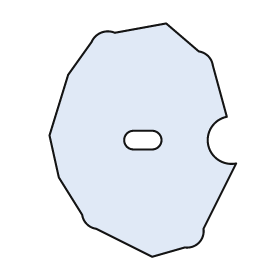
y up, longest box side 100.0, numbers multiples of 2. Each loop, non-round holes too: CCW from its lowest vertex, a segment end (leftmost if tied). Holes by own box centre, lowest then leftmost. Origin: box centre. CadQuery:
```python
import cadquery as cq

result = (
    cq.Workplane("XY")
    .moveTo(4.0, -50.0)
    .lineTo(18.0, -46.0)
    .threePointArc((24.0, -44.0), (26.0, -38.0))
    .lineTo(40.0, -10.0)
    .threePointArc((28.0, -2.0), (36.0, 10.0))
    .lineTo(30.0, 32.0)
    .threePointArc((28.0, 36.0), (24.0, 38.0))
    .lineTo(10.0, 50.0)
    .lineTo(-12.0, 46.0)
    .threePointArc((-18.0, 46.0), (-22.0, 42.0))
    .lineTo(-32.0, 28.0)
    .lineTo(-40.0, 2.0)
    .lineTo(-36.0, -16.0)
    .lineTo(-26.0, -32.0)
    .threePointArc((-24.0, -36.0), (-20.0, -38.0))
    .close()
    .moveTo(-4.0, -4.0)
    .lineTo(4.0, -4.0)
    .threePointArc((8.0, 0.0), (4.0, 4.0))
    .lineTo(-4.0, 4.0)
    .threePointArc((-8.0, 0.0), (-4.0, -4.0))
    .close()
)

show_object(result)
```